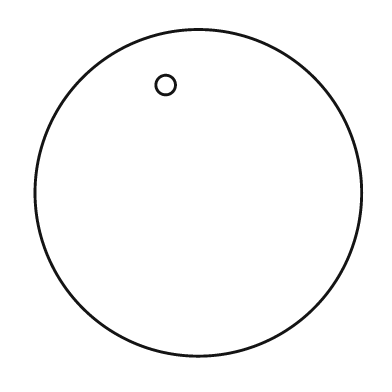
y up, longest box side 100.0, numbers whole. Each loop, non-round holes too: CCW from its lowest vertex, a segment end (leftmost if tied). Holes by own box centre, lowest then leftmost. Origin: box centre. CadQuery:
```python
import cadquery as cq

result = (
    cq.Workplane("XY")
    .moveTo(0.0, 0.0)
    .circle(50.0)
    .moveTo(-10.0, 33.0)
    .circle(3.0)
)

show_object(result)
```